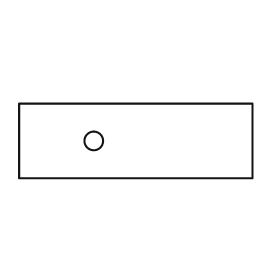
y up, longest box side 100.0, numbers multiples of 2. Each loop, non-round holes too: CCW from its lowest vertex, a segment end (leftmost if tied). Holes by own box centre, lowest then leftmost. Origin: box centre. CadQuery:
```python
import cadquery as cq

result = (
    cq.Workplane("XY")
    .moveTo(-50.0, -16.0)
    .lineTo(50.0, -16.0)
    .lineTo(50.0, 16.0)
    .lineTo(-50.0, 16.0)
    .close()
    .moveTo(-18.0, 0.0)
    .circle(4.0)
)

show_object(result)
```